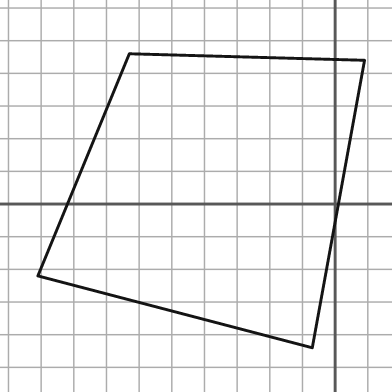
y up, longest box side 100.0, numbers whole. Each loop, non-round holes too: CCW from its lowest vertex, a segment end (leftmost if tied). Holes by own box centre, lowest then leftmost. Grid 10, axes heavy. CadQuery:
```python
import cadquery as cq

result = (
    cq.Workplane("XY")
    .moveTo(-7.0, -44.0)
    .lineTo(9.0, 44.0)
    .lineTo(-63.0, 46.0)
    .lineTo(-91.0, -22.0)
    .close()
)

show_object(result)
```